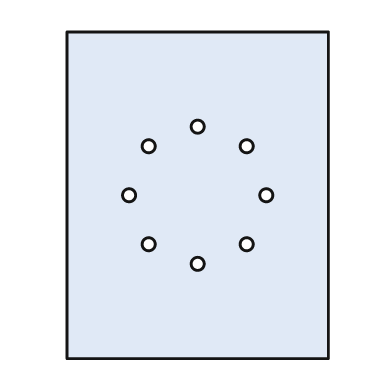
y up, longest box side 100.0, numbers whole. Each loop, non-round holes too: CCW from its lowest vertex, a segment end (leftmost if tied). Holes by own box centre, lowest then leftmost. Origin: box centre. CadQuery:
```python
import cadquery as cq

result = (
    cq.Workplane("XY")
    .moveTo(-40.0, -50.0)
    .lineTo(40.0, -50.0)
    .lineTo(40.0, 50.0)
    .lineTo(-40.0, 50.0)
    .close()
    .moveTo(0.0, -21.0)
    .circle(2.0)
    .moveTo(-15.0, -15.0)
    .circle(2.0)
    .moveTo(15.0, -15.0)
    .circle(2.0)
    .moveTo(-21.0, 0.0)
    .circle(2.0)
    .moveTo(21.0, 0.0)
    .circle(2.0)
    .moveTo(-15.0, 15.0)
    .circle(2.0)
    .moveTo(15.0, 15.0)
    .circle(2.0)
    .moveTo(0.0, 21.0)
    .circle(2.0)
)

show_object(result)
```